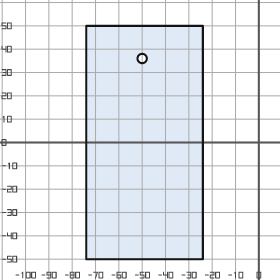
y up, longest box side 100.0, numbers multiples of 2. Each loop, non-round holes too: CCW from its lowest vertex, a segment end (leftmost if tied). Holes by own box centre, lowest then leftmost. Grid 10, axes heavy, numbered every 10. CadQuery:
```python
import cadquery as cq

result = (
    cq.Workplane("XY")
    .moveTo(-74.0, -50.0)
    .lineTo(-24.0, -50.0)
    .lineTo(-24.0, 50.0)
    .lineTo(-74.0, 50.0)
    .close()
    .moveTo(-50.0, 36.0)
    .circle(2.0)
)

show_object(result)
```